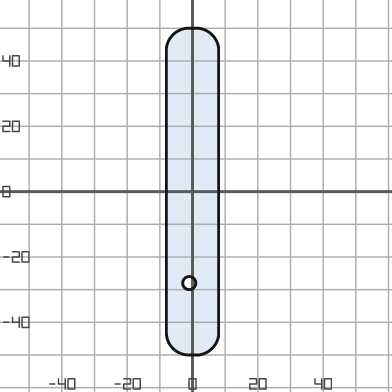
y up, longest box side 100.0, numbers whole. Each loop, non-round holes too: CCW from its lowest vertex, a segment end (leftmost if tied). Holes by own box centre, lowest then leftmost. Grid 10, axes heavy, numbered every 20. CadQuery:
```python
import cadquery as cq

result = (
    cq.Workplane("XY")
    .moveTo(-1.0, -50.0)
    .lineTo(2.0, -50.0)
    .threePointArc((6.0, -48.0), (8.0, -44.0))
    .lineTo(8.0, 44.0)
    .threePointArc((6.0, 48.0), (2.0, 50.0))
    .lineTo(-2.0, 50.0)
    .threePointArc((-6.0, 48.0), (-8.0, 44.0))
    .lineTo(-8.0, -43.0)
    .threePointArc((-6.0, -48.0), (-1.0, -50.0))
    .close()
    .moveTo(-1.0, -28.0)
    .circle(2.0)
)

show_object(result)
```